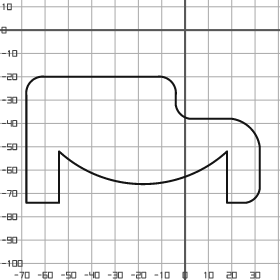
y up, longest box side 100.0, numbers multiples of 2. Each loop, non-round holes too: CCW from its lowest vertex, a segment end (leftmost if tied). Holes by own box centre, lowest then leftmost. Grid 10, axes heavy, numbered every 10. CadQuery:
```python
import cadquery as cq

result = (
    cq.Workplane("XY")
    .moveTo(-68.0, -74.0)
    .lineTo(-54.0, -74.0)
    .lineTo(-54.0, -52.0)
    .threePointArc((-18.0, -66.0), (18.0, -52.0))
    .lineTo(18.0, -74.0)
    .lineTo(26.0, -74.0)
    .threePointArc((30.0, -72.0), (32.0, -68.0))
    .lineTo(32.0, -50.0)
    .threePointArc((28.0, -42.0), (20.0, -38.0))
    .lineTo(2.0, -38.0)
    .threePointArc((-2.0, -36.0), (-4.0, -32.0))
    .lineTo(-4.0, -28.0)
    .threePointArc((-6.0, -22.0), (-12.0, -20.0))
    .lineTo(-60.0, -20.0)
    .threePointArc((-66.0, -22.0), (-68.0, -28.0))
    .close()
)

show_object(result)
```